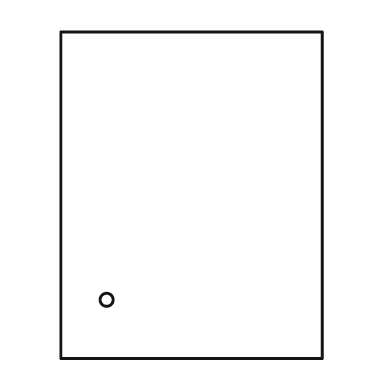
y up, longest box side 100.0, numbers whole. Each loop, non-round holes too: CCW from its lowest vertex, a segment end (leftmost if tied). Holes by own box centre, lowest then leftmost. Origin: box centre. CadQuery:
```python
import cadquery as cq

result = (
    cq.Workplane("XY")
    .moveTo(-40.0, -50.0)
    .lineTo(40.0, -50.0)
    .lineTo(40.0, 50.0)
    .lineTo(-40.0, 50.0)
    .close()
    .moveTo(-26.0, -32.0)
    .circle(2.0)
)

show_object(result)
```